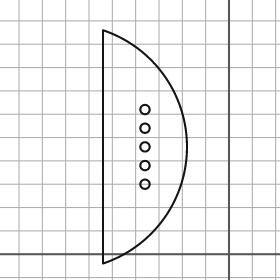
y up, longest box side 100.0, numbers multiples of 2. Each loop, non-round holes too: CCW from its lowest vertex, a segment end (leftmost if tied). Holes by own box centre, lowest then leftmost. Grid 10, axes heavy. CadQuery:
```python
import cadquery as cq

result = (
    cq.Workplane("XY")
    .moveTo(-54.0, -4.0)
    .threePointArc((-18.0, 46.0), (-54.0, 96.0))
    .close()
    .moveTo(-36.0, 30.0)
    .circle(2.0)
    .moveTo(-36.0, 38.0)
    .circle(2.0)
    .moveTo(-36.0, 46.0)
    .circle(2.0)
    .moveTo(-36.0, 54.0)
    .circle(2.0)
    .moveTo(-36.0, 62.0)
    .circle(2.0)
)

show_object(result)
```